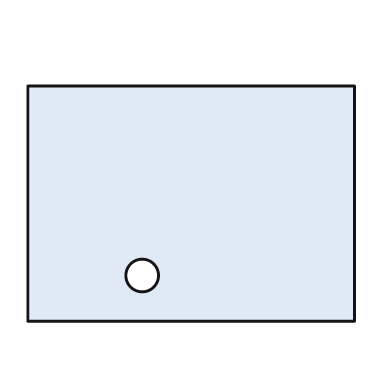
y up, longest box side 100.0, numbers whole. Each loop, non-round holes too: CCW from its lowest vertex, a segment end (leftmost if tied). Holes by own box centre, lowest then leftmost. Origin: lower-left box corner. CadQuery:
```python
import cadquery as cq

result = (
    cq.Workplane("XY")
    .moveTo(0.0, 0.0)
    .lineTo(100.0, 0.0)
    .lineTo(100.0, 72.0)
    .lineTo(0.0, 72.0)
    .close()
    .moveTo(35.0, 14.0)
    .circle(5.0)
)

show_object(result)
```